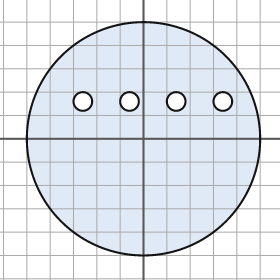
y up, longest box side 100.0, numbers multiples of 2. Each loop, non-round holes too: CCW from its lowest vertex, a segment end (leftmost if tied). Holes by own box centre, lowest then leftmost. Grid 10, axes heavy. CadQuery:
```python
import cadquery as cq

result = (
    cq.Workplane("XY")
    .moveTo(0.0, 0.0)
    .circle(50.0)
    .moveTo(-26.0, 16.0)
    .circle(4.0)
    .moveTo(-6.0, 16.0)
    .circle(4.0)
    .moveTo(14.0, 16.0)
    .circle(4.0)
    .moveTo(34.0, 16.0)
    .circle(4.0)
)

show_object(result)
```